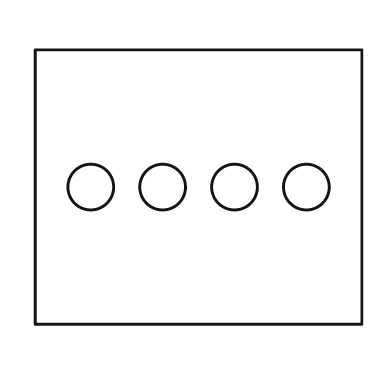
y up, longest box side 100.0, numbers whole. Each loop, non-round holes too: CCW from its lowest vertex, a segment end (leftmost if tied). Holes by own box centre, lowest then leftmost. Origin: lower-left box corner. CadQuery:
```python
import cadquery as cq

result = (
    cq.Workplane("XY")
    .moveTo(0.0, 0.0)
    .lineTo(100.0, 0.0)
    .lineTo(100.0, 84.0)
    .lineTo(0.0, 84.0)
    .close()
    .moveTo(17.0, 42.0)
    .circle(7.0)
    .moveTo(39.0, 42.0)
    .circle(7.0)
    .moveTo(61.0, 42.0)
    .circle(7.0)
    .moveTo(83.0, 42.0)
    .circle(7.0)
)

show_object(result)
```